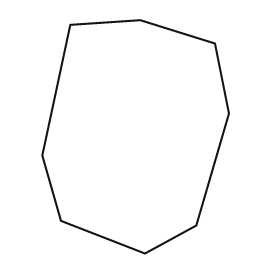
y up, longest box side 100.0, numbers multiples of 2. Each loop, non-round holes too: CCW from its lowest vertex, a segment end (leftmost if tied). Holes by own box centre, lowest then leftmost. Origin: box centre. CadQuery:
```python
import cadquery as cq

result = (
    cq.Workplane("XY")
    .moveTo(4.0, -50.0)
    .lineTo(26.0, -38.0)
    .lineTo(40.0, 10.0)
    .lineTo(34.0, 40.0)
    .lineTo(2.0, 50.0)
    .lineTo(-28.0, 48.0)
    .lineTo(-40.0, -8.0)
    .lineTo(-32.0, -36.0)
    .close()
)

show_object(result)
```